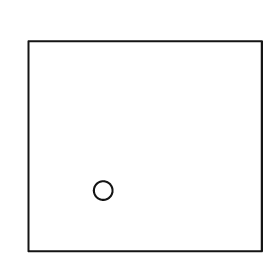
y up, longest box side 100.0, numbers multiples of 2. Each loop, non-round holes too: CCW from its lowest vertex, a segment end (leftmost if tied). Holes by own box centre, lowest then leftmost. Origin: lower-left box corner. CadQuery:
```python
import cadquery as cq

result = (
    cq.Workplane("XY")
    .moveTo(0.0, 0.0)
    .lineTo(100.0, 0.0)
    .lineTo(100.0, 90.0)
    .lineTo(0.0, 90.0)
    .close()
    .moveTo(32.0, 26.0)
    .circle(4.0)
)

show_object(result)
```